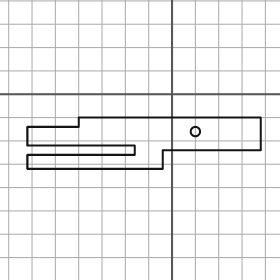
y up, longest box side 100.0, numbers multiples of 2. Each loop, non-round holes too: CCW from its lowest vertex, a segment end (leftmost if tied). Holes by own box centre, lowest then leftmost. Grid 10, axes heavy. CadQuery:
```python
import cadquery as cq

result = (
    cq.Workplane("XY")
    .moveTo(-62.0, -32.0)
    .lineTo(-4.0, -32.0)
    .lineTo(-4.0, -24.0)
    .lineTo(38.0, -24.0)
    .lineTo(38.0, -10.0)
    .lineTo(-40.0, -10.0)
    .lineTo(-40.0, -14.0)
    .lineTo(-62.0, -14.0)
    .lineTo(-62.0, -22.0)
    .lineTo(-16.0, -22.0)
    .lineTo(-16.0, -26.0)
    .lineTo(-62.0, -26.0)
    .close()
    .moveTo(10.0, -16.0)
    .circle(2.0)
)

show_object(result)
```